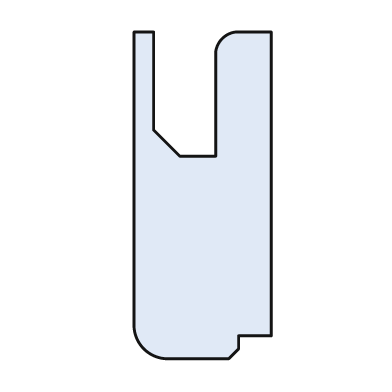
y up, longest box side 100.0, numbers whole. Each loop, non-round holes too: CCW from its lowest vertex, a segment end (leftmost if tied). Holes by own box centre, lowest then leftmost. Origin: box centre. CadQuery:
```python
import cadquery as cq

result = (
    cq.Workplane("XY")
    .moveTo(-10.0, -50.0)
    .lineTo(8.0, -50.0)
    .lineTo(11.0, -47.0)
    .lineTo(11.0, -43.0)
    .lineTo(21.0, -43.0)
    .lineTo(21.0, 50.0)
    .lineTo(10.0, 50.0)
    .threePointArc((6.0, 48.0), (4.0, 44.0))
    .lineTo(4.0, 12.0)
    .lineTo(-7.0, 12.0)
    .lineTo(-15.0, 20.0)
    .lineTo(-15.0, 50.0)
    .lineTo(-21.0, 50.0)
    .lineTo(-21.0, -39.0)
    .threePointArc((-18.0, -47.0), (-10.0, -50.0))
    .close()
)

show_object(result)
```